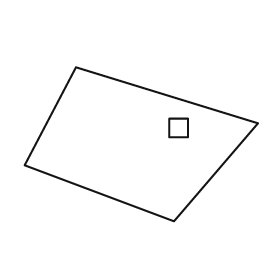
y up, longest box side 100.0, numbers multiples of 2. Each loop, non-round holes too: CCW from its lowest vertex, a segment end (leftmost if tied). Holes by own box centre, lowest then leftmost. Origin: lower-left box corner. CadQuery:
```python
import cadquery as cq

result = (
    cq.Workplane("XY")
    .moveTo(64.0, 0.0)
    .lineTo(100.0, 42.0)
    .lineTo(22.0, 66.0)
    .lineTo(0.0, 24.0)
    .close()
    .moveTo(62.0, 36.0)
    .lineTo(70.0, 36.0)
    .lineTo(70.0, 44.0)
    .lineTo(62.0, 44.0)
    .close()
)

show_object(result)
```